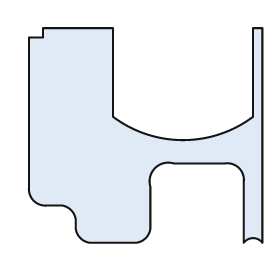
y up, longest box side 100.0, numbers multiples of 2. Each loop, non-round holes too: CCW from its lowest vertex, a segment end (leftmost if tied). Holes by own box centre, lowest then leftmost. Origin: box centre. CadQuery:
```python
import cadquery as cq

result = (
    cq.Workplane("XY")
    .moveTo(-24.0, -46.0)
    .lineTo(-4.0, -46.0)
    .threePointArc((0.0, -44.0), (2.0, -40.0))
    .lineTo(2.0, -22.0)
    .threePointArc((4.0, -14.0), (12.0, -12.0))
    .lineTo(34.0, -12.0)
    .threePointArc((40.0, -14.0), (42.0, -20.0))
    .lineTo(42.0, -46.0)
    .threePointArc((46.0, -44.0), (50.0, -46.0))
    .lineTo(50.0, 46.0)
    .lineTo(46.0, 46.0)
    .lineTo(46.0, 8.0)
    .threePointArc((16.0, -2.0), (-14.0, 8.0))
    .lineTo(-14.0, 46.0)
    .lineTo(-44.0, 46.0)
    .lineTo(-44.0, 42.0)
    .lineTo(-50.0, 42.0)
    .lineTo(-50.0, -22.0)
    .threePointArc((-48.0, -28.0), (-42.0, -30.0))
    .lineTo(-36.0, -30.0)
    .threePointArc((-32.0, -32.0), (-30.0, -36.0))
    .lineTo(-30.0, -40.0)
    .threePointArc((-28.0, -44.0), (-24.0, -46.0))
    .close()
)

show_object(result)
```